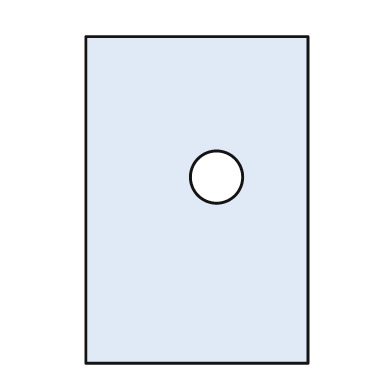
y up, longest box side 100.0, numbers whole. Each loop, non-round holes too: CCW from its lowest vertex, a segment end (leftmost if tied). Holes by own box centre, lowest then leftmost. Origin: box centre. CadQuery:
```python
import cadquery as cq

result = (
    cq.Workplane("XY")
    .moveTo(-34.0, -50.0)
    .lineTo(34.0, -50.0)
    .lineTo(34.0, 50.0)
    .lineTo(-34.0, 50.0)
    .close()
    .moveTo(6.0, 7.0)
    .circle(8.0)
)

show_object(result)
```